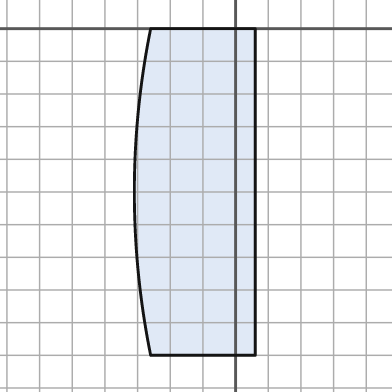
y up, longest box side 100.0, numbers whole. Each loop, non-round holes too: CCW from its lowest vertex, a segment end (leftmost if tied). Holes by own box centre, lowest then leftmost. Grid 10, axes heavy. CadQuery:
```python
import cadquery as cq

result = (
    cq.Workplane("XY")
    .moveTo(-26.0, -100.0)
    .lineTo(6.0, -100.0)
    .lineTo(6.0, 0.0)
    .lineTo(-26.0, 0.0)
    .threePointArc((-31.0, -50.0), (-26.0, -100.0))
    .close()
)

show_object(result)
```